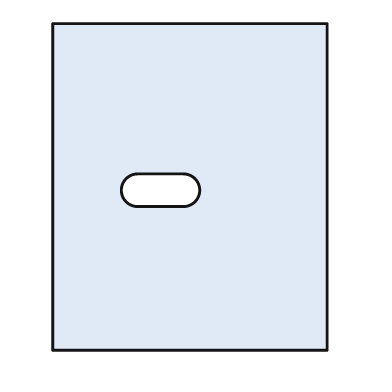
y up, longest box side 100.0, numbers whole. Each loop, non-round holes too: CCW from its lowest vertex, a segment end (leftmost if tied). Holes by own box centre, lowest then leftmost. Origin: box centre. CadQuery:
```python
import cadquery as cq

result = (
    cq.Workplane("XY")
    .moveTo(-42.0, -50.0)
    .lineTo(42.0, -50.0)
    .lineTo(42.0, 50.0)
    .lineTo(-42.0, 50.0)
    .close()
    .moveTo(-16.0, -6.0)
    .lineTo(-2.0, -6.0)
    .threePointArc((3.0, -1.0), (-2.0, 4.0))
    .lineTo(-16.0, 4.0)
    .threePointArc((-21.0, -1.0), (-16.0, -6.0))
    .close()
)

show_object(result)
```